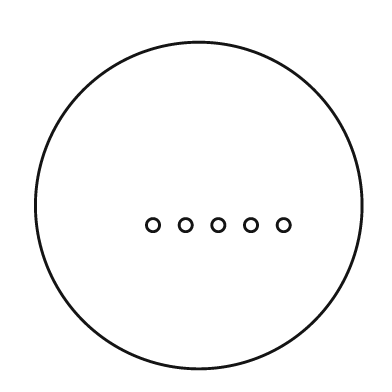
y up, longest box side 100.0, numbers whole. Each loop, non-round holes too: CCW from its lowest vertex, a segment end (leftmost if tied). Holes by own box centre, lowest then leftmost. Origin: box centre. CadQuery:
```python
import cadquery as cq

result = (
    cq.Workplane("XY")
    .moveTo(0.0, 0.0)
    .circle(50.0)
    .moveTo(-14.0, -6.0)
    .circle(2.0)
    .moveTo(-4.0, -6.0)
    .circle(2.0)
    .moveTo(6.0, -6.0)
    .circle(2.0)
    .moveTo(16.0, -6.0)
    .circle(2.0)
    .moveTo(26.0, -6.0)
    .circle(2.0)
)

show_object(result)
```